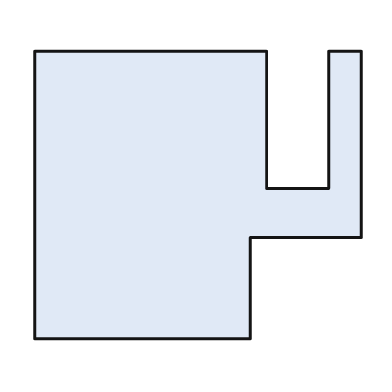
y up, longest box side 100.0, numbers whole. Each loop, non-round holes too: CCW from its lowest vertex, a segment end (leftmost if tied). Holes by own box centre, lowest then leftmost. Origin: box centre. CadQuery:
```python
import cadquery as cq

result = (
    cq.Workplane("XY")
    .moveTo(-50.0, -44.0)
    .lineTo(16.0, -44.0)
    .lineTo(16.0, -13.0)
    .lineTo(50.0, -13.0)
    .lineTo(50.0, 44.0)
    .lineTo(40.0, 44.0)
    .lineTo(40.0, 2.0)
    .lineTo(21.0, 2.0)
    .lineTo(21.0, 44.0)
    .lineTo(-50.0, 44.0)
    .close()
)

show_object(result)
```